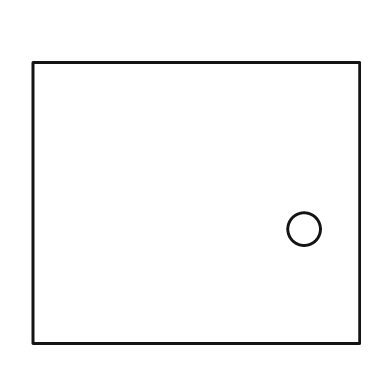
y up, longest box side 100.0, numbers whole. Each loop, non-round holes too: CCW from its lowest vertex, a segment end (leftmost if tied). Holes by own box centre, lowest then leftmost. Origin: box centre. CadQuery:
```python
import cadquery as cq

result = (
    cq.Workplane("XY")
    .moveTo(-50.0, -43.0)
    .lineTo(50.0, -43.0)
    .lineTo(50.0, 43.0)
    .lineTo(-50.0, 43.0)
    .close()
    .moveTo(33.0, -8.0)
    .circle(5.0)
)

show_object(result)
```